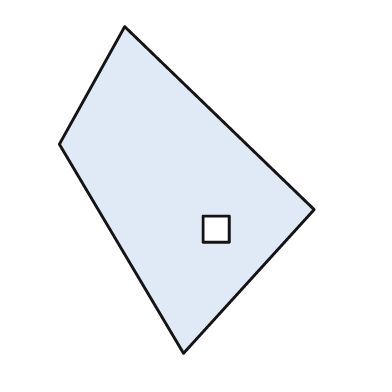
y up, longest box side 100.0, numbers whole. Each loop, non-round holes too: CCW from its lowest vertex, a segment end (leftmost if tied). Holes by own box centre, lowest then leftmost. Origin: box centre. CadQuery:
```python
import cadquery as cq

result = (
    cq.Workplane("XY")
    .moveTo(-1.0, -50.0)
    .lineTo(39.0, -6.0)
    .lineTo(-19.0, 50.0)
    .lineTo(-39.0, 14.0)
    .close()
    .moveTo(5.0, -16.0)
    .lineTo(13.0, -16.0)
    .lineTo(13.0, -8.0)
    .lineTo(5.0, -8.0)
    .close()
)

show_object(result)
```